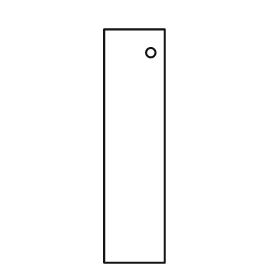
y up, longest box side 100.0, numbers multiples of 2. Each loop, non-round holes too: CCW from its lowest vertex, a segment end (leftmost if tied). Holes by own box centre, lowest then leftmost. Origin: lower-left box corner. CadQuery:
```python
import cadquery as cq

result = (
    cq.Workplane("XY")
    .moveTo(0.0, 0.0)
    .lineTo(26.0, 0.0)
    .lineTo(26.0, 100.0)
    .lineTo(0.0, 100.0)
    .close()
    .moveTo(20.0, 90.0)
    .circle(2.0)
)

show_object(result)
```